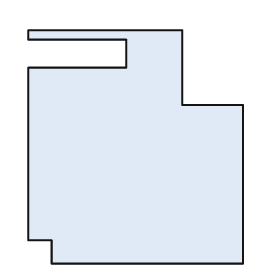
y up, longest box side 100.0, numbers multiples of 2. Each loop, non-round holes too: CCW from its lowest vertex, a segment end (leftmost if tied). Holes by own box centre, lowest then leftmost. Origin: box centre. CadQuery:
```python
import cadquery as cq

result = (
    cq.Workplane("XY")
    .moveTo(-36.0, -50.0)
    .lineTo(46.0, -50.0)
    .lineTo(46.0, 18.0)
    .lineTo(20.0, 18.0)
    .lineTo(20.0, 50.0)
    .lineTo(-46.0, 50.0)
    .lineTo(-46.0, 46.0)
    .lineTo(-4.0, 46.0)
    .lineTo(-4.0, 34.0)
    .lineTo(-46.0, 34.0)
    .lineTo(-46.0, -40.0)
    .lineTo(-36.0, -40.0)
    .close()
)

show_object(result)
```